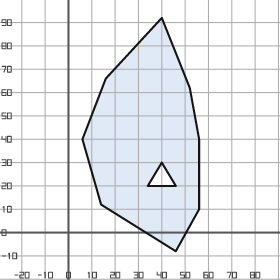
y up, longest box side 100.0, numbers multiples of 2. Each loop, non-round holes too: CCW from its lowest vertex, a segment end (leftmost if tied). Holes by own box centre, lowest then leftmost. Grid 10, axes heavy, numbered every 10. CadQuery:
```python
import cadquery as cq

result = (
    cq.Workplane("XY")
    .moveTo(46.0, -8.0)
    .lineTo(56.0, 10.0)
    .lineTo(56.0, 40.0)
    .lineTo(52.0, 62.0)
    .lineTo(40.0, 92.0)
    .lineTo(16.0, 66.0)
    .lineTo(6.0, 40.0)
    .lineTo(14.0, 12.0)
    .close()
    .moveTo(34.0, 20.0)
    .lineTo(46.0, 20.0)
    .lineTo(40.0, 30.0)
    .close()
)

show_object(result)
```